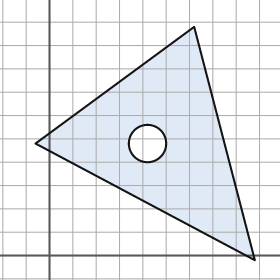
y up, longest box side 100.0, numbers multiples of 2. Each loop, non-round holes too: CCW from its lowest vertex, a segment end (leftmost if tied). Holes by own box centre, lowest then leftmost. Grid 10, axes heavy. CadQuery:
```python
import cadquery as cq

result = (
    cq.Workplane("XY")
    .moveTo(88.0, -2.0)
    .lineTo(62.0, 98.0)
    .lineTo(-6.0, 48.0)
    .close()
    .moveTo(42.0, 48.0)
    .circle(8.0)
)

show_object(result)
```